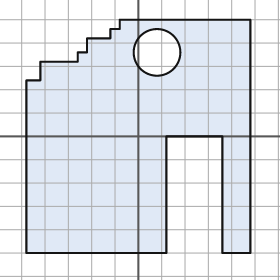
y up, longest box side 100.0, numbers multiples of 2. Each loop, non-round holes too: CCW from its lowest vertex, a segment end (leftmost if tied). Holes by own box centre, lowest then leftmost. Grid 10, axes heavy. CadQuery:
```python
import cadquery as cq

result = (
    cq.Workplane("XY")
    .moveTo(-48.0, -50.0)
    .lineTo(12.0, -50.0)
    .lineTo(12.0, 0.0)
    .lineTo(36.0, 0.0)
    .lineTo(36.0, -50.0)
    .lineTo(48.0, -50.0)
    .lineTo(48.0, 50.0)
    .lineTo(-8.0, 50.0)
    .lineTo(-8.0, 46.0)
    .lineTo(-12.0, 46.0)
    .lineTo(-12.0, 42.0)
    .lineTo(-22.0, 42.0)
    .lineTo(-22.0, 36.0)
    .lineTo(-26.0, 36.0)
    .lineTo(-26.0, 32.0)
    .lineTo(-42.0, 32.0)
    .lineTo(-42.0, 24.0)
    .lineTo(-48.0, 24.0)
    .close()
    .moveTo(8.0, 36.0)
    .circle(10.0)
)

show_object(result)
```